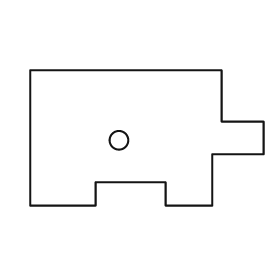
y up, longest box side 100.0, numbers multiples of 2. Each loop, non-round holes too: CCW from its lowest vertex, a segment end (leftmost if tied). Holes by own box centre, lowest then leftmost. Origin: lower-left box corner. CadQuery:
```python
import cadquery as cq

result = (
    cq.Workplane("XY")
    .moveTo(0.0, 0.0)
    .lineTo(28.0, 0.0)
    .lineTo(28.0, 10.0)
    .lineTo(58.0, 10.0)
    .lineTo(58.0, 0.0)
    .lineTo(78.0, 0.0)
    .lineTo(78.0, 22.0)
    .lineTo(100.0, 22.0)
    .lineTo(100.0, 36.0)
    .lineTo(82.0, 36.0)
    .lineTo(82.0, 58.0)
    .lineTo(0.0, 58.0)
    .close()
    .moveTo(38.0, 28.0)
    .circle(4.0)
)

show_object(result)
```